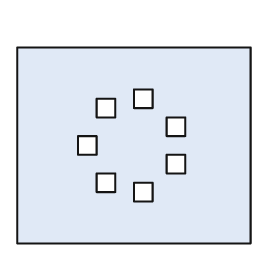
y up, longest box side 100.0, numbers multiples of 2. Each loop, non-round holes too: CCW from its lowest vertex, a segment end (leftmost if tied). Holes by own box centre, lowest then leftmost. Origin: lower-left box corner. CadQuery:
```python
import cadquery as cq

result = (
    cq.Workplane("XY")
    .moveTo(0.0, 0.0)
    .lineTo(100.0, 0.0)
    .lineTo(100.0, 84.0)
    .lineTo(0.0, 84.0)
    .close()
    .moveTo(50.0, 18.0)
    .lineTo(58.0, 18.0)
    .lineTo(58.0, 26.0)
    .lineTo(50.0, 26.0)
    .close()
    .moveTo(34.0, 22.0)
    .lineTo(42.0, 22.0)
    .lineTo(42.0, 30.0)
    .lineTo(34.0, 30.0)
    .close()
    .moveTo(64.0, 30.0)
    .lineTo(72.0, 30.0)
    .lineTo(72.0, 38.0)
    .lineTo(64.0, 38.0)
    .close()
    .moveTo(26.0, 38.0)
    .lineTo(34.0, 38.0)
    .lineTo(34.0, 46.0)
    .lineTo(26.0, 46.0)
    .close()
    .moveTo(64.0, 46.0)
    .lineTo(72.0, 46.0)
    .lineTo(72.0, 54.0)
    .lineTo(64.0, 54.0)
    .close()
    .moveTo(34.0, 54.0)
    .lineTo(42.0, 54.0)
    .lineTo(42.0, 62.0)
    .lineTo(34.0, 62.0)
    .close()
    .moveTo(50.0, 58.0)
    .lineTo(58.0, 58.0)
    .lineTo(58.0, 66.0)
    .lineTo(50.0, 66.0)
    .close()
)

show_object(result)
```